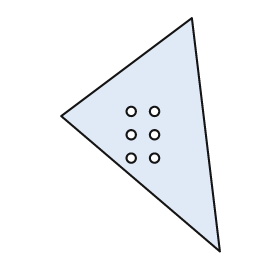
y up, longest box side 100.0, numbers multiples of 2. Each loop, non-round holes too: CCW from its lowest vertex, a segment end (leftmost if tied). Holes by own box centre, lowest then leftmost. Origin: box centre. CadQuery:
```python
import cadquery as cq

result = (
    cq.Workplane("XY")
    .moveTo(34.0, -50.0)
    .lineTo(22.0, 50.0)
    .lineTo(-34.0, 8.0)
    .close()
    .moveTo(-4.0, -10.0)
    .circle(2.0)
    .moveTo(6.0, -10.0)
    .circle(2.0)
    .moveTo(-4.0, 0.0)
    .circle(2.0)
    .moveTo(6.0, 0.0)
    .circle(2.0)
    .moveTo(-4.0, 10.0)
    .circle(2.0)
    .moveTo(6.0, 10.0)
    .circle(2.0)
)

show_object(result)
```